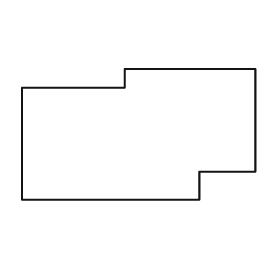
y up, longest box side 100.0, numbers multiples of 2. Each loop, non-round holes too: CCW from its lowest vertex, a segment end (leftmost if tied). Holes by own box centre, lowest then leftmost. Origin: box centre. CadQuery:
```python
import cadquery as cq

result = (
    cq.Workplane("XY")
    .moveTo(-50.0, -28.0)
    .lineTo(26.0, -28.0)
    .lineTo(26.0, -16.0)
    .lineTo(50.0, -16.0)
    .lineTo(50.0, 28.0)
    .lineTo(-6.0, 28.0)
    .lineTo(-6.0, 20.0)
    .lineTo(-50.0, 20.0)
    .close()
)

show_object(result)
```